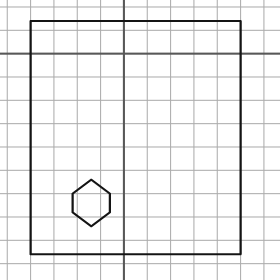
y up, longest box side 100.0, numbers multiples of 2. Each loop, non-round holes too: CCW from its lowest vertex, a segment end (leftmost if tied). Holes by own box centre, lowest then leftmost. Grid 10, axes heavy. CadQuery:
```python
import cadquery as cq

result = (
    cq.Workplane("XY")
    .moveTo(-40.0, -86.0)
    .lineTo(50.0, -86.0)
    .lineTo(50.0, 14.0)
    .lineTo(-40.0, 14.0)
    .close()
    .moveTo(-14.0, -74.0)
    .lineTo(-6.0, -68.0)
    .lineTo(-6.0, -60.0)
    .lineTo(-14.0, -54.0)
    .lineTo(-22.0, -60.0)
    .lineTo(-22.0, -68.0)
    .close()
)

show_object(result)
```